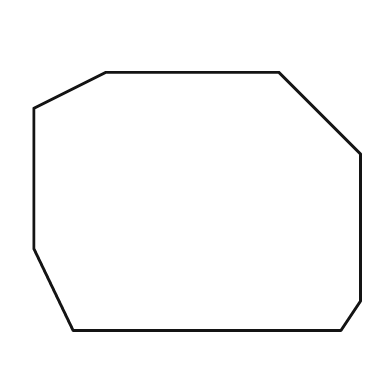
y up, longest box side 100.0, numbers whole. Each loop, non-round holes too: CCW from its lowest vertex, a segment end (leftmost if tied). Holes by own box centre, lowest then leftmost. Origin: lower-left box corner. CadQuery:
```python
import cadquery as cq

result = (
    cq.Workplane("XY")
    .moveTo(12.0, 0.0)
    .lineTo(94.0, 0.0)
    .lineTo(100.0, 9.0)
    .lineTo(100.0, 54.0)
    .lineTo(75.0, 79.0)
    .lineTo(22.0, 79.0)
    .lineTo(0.0, 68.0)
    .lineTo(0.0, 25.0)
    .close()
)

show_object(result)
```